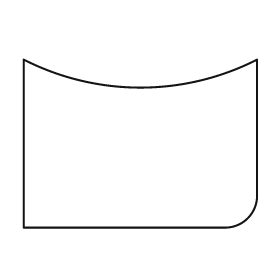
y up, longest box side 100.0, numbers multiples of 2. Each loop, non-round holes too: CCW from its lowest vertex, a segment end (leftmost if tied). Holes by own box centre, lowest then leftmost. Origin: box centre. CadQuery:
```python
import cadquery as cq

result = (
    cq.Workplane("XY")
    .moveTo(-50.0, -36.0)
    .lineTo(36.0, -36.0)
    .threePointArc((46.0, -32.0), (50.0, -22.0))
    .lineTo(50.0, 36.0)
    .threePointArc((0.0, 24.0), (-50.0, 36.0))
    .close()
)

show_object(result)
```